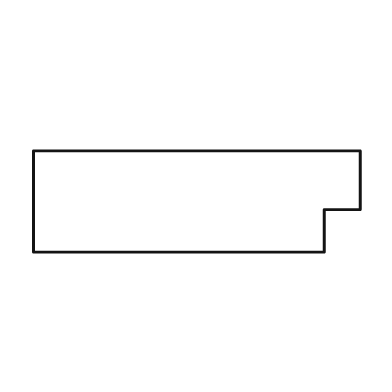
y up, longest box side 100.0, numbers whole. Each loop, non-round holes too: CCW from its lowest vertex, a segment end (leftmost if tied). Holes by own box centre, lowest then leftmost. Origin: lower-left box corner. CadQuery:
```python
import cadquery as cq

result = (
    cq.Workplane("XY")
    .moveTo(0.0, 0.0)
    .lineTo(89.0, 0.0)
    .lineTo(89.0, 13.0)
    .lineTo(100.0, 13.0)
    .lineTo(100.0, 31.0)
    .lineTo(0.0, 31.0)
    .close()
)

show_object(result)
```